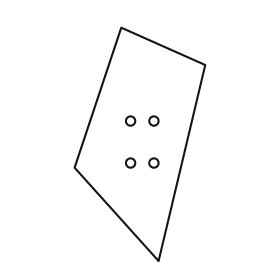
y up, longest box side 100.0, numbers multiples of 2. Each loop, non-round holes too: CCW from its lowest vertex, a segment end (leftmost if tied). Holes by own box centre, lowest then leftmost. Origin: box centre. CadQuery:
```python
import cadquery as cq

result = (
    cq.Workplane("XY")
    .moveTo(8.0, -50.0)
    .lineTo(28.0, 34.0)
    .lineTo(-8.0, 50.0)
    .lineTo(-28.0, -10.0)
    .close()
    .moveTo(-4.0, -8.0)
    .circle(2.0)
    .moveTo(6.0, -8.0)
    .circle(2.0)
    .moveTo(-4.0, 10.0)
    .circle(2.0)
    .moveTo(6.0, 10.0)
    .circle(2.0)
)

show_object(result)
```